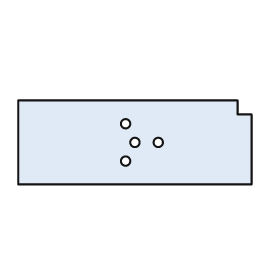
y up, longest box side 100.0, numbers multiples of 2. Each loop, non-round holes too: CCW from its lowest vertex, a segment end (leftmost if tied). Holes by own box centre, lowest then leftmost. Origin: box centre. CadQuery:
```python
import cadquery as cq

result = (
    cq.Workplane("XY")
    .moveTo(-50.0, -18.0)
    .lineTo(50.0, -18.0)
    .lineTo(50.0, 12.0)
    .lineTo(44.0, 12.0)
    .lineTo(44.0, 18.0)
    .lineTo(-50.0, 18.0)
    .close()
    .moveTo(-4.0, -8.0)
    .circle(2.0)
    .moveTo(0.0, 0.0)
    .circle(2.0)
    .moveTo(10.0, 0.0)
    .circle(2.0)
    .moveTo(-4.0, 8.0)
    .circle(2.0)
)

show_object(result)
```